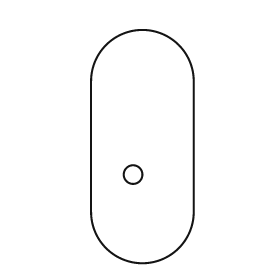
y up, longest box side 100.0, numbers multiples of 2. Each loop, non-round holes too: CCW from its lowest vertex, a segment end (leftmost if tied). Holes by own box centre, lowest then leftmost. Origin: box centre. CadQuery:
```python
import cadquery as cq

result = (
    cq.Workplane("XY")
    .moveTo(-22.0, -28.0)
    .threePointArc((0.0, -50.0), (22.0, -28.0))
    .lineTo(22.0, 28.0)
    .threePointArc((0.0, 50.0), (-22.0, 28.0))
    .close()
    .moveTo(-4.0, -12.0)
    .circle(4.0)
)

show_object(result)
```